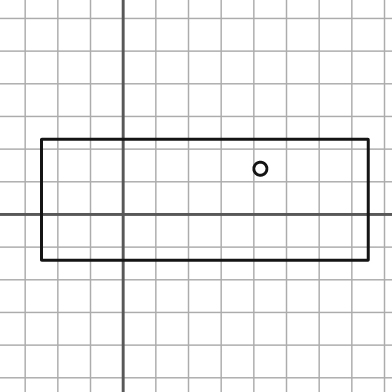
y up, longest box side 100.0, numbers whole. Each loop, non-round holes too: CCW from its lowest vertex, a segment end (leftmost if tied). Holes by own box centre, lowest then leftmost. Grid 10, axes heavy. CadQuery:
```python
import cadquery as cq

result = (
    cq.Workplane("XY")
    .moveTo(-25.0, -14.0)
    .lineTo(75.0, -14.0)
    .lineTo(75.0, 23.0)
    .lineTo(-25.0, 23.0)
    .close()
    .moveTo(42.0, 14.0)
    .circle(2.0)
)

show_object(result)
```